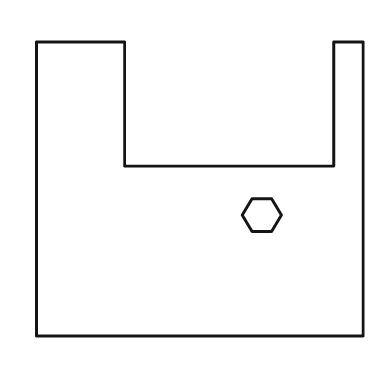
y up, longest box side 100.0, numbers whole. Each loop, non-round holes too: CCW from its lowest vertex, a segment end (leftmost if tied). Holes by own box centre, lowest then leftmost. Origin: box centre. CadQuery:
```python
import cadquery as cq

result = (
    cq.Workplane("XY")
    .moveTo(-50.0, -45.0)
    .lineTo(50.0, -45.0)
    .lineTo(50.0, 45.0)
    .lineTo(41.0, 45.0)
    .lineTo(41.0, 7.0)
    .lineTo(-23.0, 7.0)
    .lineTo(-23.0, 45.0)
    .lineTo(-50.0, 45.0)
    .close()
    .moveTo(16.0, -13.0)
    .lineTo(22.0, -13.0)
    .lineTo(25.0, -8.0)
    .lineTo(22.0, -3.0)
    .lineTo(16.0, -3.0)
    .lineTo(13.0, -8.0)
    .close()
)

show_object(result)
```